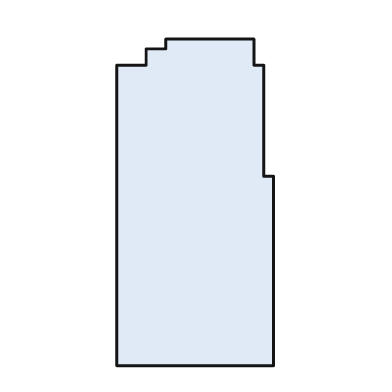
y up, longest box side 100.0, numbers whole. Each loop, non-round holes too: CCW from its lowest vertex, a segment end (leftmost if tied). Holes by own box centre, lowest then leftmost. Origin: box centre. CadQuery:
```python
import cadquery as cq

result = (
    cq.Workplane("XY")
    .moveTo(-24.0, -50.0)
    .lineTo(24.0, -50.0)
    .lineTo(24.0, 8.0)
    .lineTo(21.0, 8.0)
    .lineTo(21.0, 42.0)
    .lineTo(18.0, 42.0)
    .lineTo(18.0, 50.0)
    .lineTo(-9.0, 50.0)
    .lineTo(-9.0, 47.0)
    .lineTo(-15.0, 47.0)
    .lineTo(-15.0, 42.0)
    .lineTo(-24.0, 42.0)
    .close()
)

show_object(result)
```